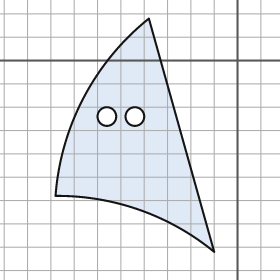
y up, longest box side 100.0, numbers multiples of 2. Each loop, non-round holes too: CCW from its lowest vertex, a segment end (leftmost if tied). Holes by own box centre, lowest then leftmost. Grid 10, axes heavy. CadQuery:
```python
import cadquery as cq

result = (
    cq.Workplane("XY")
    .moveTo(-10.0, -82.0)
    .lineTo(-38.0, 18.0)
    .threePointArc((-66.0, -16.0), (-78.0, -58.0))
    .threePointArc((-42.0, -64.0), (-10.0, -82.0))
    .close()
    .moveTo(-56.0, -24.0)
    .circle(4.0)
    .moveTo(-44.0, -24.0)
    .circle(4.0)
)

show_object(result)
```